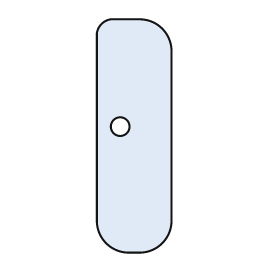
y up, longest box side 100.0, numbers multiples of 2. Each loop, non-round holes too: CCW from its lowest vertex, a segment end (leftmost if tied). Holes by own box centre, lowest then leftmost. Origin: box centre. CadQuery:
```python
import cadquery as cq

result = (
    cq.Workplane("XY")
    .moveTo(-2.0, -50.0)
    .lineTo(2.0, -50.0)
    .threePointArc((12.0, -46.0), (16.0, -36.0))
    .lineTo(16.0, 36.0)
    .threePointArc((12.0, 46.0), (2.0, 50.0))
    .lineTo(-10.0, 50.0)
    .threePointArc((-14.0, 48.0), (-16.0, 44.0))
    .lineTo(-16.0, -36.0)
    .threePointArc((-12.0, -46.0), (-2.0, -50.0))
    .close()
    .moveTo(-6.0, 4.0)
    .circle(4.0)
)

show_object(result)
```